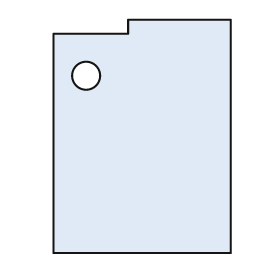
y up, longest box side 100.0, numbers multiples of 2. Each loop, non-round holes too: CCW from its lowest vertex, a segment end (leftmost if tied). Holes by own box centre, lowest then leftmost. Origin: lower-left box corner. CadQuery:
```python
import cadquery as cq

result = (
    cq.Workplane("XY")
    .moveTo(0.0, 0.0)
    .lineTo(76.0, 0.0)
    .lineTo(76.0, 100.0)
    .lineTo(32.0, 100.0)
    .lineTo(32.0, 94.0)
    .lineTo(0.0, 94.0)
    .close()
    .moveTo(14.0, 76.0)
    .circle(6.0)
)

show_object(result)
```